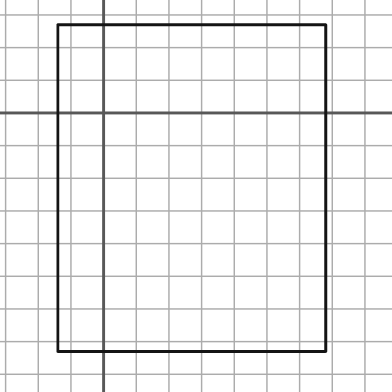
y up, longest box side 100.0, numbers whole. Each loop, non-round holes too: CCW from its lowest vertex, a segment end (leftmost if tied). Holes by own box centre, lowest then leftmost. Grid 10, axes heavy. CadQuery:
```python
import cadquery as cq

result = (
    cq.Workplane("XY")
    .moveTo(-14.0, -73.0)
    .lineTo(68.0, -73.0)
    .lineTo(68.0, 27.0)
    .lineTo(-14.0, 27.0)
    .close()
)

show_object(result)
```